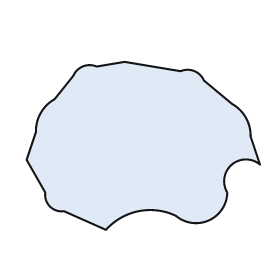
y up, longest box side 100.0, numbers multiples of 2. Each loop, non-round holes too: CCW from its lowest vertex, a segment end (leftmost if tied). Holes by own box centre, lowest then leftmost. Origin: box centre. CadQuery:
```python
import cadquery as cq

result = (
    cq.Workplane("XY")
    .moveTo(-16.0, -36.0)
    .threePointArc((-2.0, -28.0), (14.0, -30.0))
    .threePointArc((28.0, -32.0), (36.0, -20.0))
    .threePointArc((38.0, -8.0), (50.0, -8.0))
    .lineTo(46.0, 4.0)
    .threePointArc((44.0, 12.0), (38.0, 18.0))
    .lineTo(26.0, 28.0)
    .threePointArc((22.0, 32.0), (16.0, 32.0))
    .lineTo(-8.0, 36.0)
    .lineTo(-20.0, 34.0)
    .threePointArc((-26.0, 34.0), (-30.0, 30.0))
    .lineTo(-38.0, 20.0)
    .threePointArc((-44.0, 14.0), (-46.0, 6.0))
    .lineTo(-50.0, -6.0)
    .lineTo(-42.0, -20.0)
    .threePointArc((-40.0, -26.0), (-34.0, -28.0))
    .close()
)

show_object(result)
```